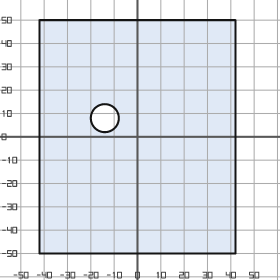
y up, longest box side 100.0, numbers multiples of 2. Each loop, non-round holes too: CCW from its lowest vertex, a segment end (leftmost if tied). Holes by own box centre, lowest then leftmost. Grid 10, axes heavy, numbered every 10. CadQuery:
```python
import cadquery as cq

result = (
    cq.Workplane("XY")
    .moveTo(-42.0, -50.0)
    .lineTo(42.0, -50.0)
    .lineTo(42.0, 50.0)
    .lineTo(-42.0, 50.0)
    .close()
    .moveTo(-14.0, 8.0)
    .circle(6.0)
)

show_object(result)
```